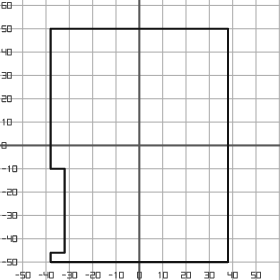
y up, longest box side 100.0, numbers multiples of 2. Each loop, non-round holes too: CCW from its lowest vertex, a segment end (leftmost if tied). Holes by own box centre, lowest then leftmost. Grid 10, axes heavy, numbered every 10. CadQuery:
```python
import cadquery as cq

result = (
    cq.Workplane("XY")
    .moveTo(-38.0, -50.0)
    .lineTo(38.0, -50.0)
    .lineTo(38.0, 50.0)
    .lineTo(-38.0, 50.0)
    .lineTo(-38.0, -10.0)
    .lineTo(-32.0, -10.0)
    .lineTo(-32.0, -46.0)
    .lineTo(-38.0, -46.0)
    .close()
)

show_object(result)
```